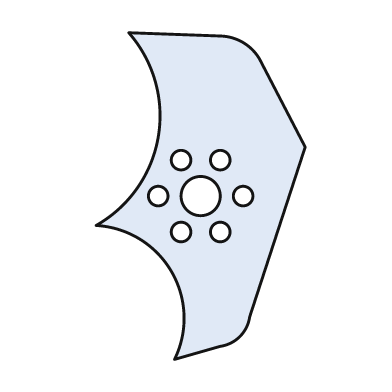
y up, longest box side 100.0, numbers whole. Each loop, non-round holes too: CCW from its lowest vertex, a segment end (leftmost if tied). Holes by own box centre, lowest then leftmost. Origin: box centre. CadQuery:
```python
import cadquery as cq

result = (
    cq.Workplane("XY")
    .moveTo(-8.0, -50.0)
    .lineTo(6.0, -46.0)
    .threePointArc((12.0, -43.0), (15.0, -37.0))
    .lineTo(32.0, 15.0)
    .lineTo(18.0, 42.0)
    .threePointArc((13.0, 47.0), (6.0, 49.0))
    .lineTo(-22.0, 50.0)
    .threePointArc((-13.0, 18.0), (-32.0, -9.0))
    .threePointArc((-9.0, -23.0), (-8.0, -50.0))
    .close()
    .moveTo(-6.0, -11.0)
    .circle(3.0)
    .moveTo(6.0, -11.0)
    .circle(3.0)
    .moveTo(-13.0, 0.0)
    .circle(3.0)
    .moveTo(0.0, 0.0)
    .circle(6.0)
    .moveTo(13.0, 0.0)
    .circle(3.0)
    .moveTo(-6.0, 11.0)
    .circle(3.0)
    .moveTo(6.0, 11.0)
    .circle(3.0)
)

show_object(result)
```